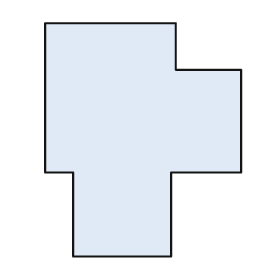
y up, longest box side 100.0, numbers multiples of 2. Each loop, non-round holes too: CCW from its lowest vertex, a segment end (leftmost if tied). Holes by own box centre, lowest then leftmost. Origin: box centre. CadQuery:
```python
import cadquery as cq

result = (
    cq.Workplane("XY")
    .moveTo(-30.0, -50.0)
    .lineTo(12.0, -50.0)
    .lineTo(12.0, -14.0)
    .lineTo(42.0, -14.0)
    .lineTo(42.0, 30.0)
    .lineTo(14.0, 30.0)
    .lineTo(14.0, 50.0)
    .lineTo(-42.0, 50.0)
    .lineTo(-42.0, -14.0)
    .lineTo(-30.0, -14.0)
    .close()
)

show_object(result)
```